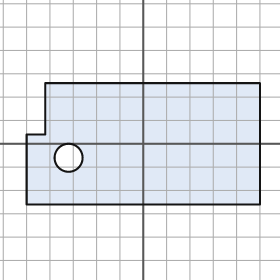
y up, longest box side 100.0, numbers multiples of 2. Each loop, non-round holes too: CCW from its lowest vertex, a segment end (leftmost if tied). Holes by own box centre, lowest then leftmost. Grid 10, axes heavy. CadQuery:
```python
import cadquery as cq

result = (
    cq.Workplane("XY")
    .moveTo(-50.0, -26.0)
    .lineTo(50.0, -26.0)
    .lineTo(50.0, 26.0)
    .lineTo(-42.0, 26.0)
    .lineTo(-42.0, 4.0)
    .lineTo(-50.0, 4.0)
    .close()
    .moveTo(-32.0, -6.0)
    .circle(6.0)
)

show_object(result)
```